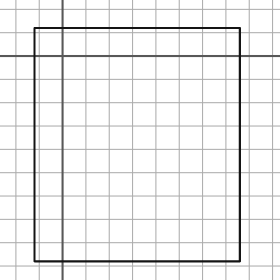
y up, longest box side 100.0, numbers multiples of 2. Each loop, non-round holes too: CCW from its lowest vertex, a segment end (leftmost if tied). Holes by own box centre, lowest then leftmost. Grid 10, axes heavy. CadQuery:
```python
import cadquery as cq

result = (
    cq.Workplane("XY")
    .moveTo(-12.0, -88.0)
    .lineTo(76.0, -88.0)
    .lineTo(76.0, 12.0)
    .lineTo(-12.0, 12.0)
    .close()
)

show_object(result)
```